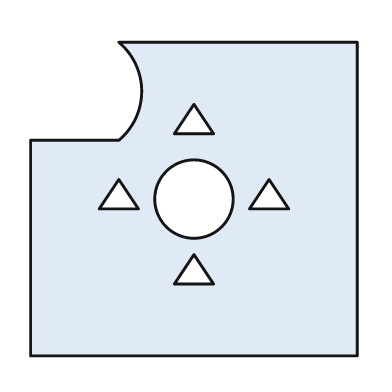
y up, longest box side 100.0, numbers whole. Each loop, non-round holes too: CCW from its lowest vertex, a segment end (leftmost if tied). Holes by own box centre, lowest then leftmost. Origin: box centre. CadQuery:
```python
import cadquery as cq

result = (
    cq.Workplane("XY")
    .moveTo(-50.0, -48.0)
    .lineTo(50.0, -48.0)
    .lineTo(50.0, 48.0)
    .lineTo(-23.0, 48.0)
    .threePointArc((-16.0, 33.0), (-23.0, 18.0))
    .lineTo(-50.0, 18.0)
    .close()
    .moveTo(-6.0, -26.0)
    .lineTo(6.0, -26.0)
    .lineTo(0.0, -17.0)
    .close()
    .moveTo(0.0, 0.0)
    .circle(12.0)
    .moveTo(-29.0, -3.0)
    .lineTo(-17.0, -3.0)
    .lineTo(-23.0, 6.0)
    .close()
    .moveTo(17.0, -3.0)
    .lineTo(29.0, -3.0)
    .lineTo(23.0, 6.0)
    .close()
    .moveTo(-6.0, 20.0)
    .lineTo(6.0, 20.0)
    .lineTo(0.0, 29.0)
    .close()
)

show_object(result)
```